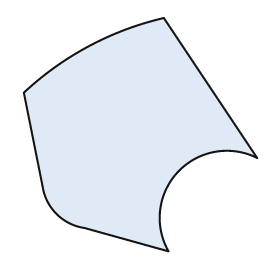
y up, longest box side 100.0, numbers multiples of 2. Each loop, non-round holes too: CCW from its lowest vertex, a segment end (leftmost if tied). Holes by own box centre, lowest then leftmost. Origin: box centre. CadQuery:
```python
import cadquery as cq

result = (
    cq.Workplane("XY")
    .moveTo(12.0, -50.0)
    .threePointArc((16.0, -16.0), (50.0, -10.0))
    .lineTo(10.0, 50.0)
    .threePointArc((-22.0, 38.0), (-50.0, 18.0))
    .lineTo(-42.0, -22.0)
    .threePointArc((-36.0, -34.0), (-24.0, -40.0))
    .close()
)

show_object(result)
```